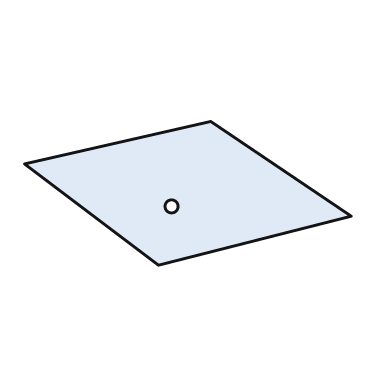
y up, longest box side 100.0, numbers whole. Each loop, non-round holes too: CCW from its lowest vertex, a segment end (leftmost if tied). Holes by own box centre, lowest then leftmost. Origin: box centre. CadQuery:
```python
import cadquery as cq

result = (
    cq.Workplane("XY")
    .moveTo(-9.0, -22.0)
    .lineTo(50.0, -7.0)
    .lineTo(7.0, 22.0)
    .lineTo(-50.0, 9.0)
    .close()
    .moveTo(-5.0, -4.0)
    .circle(2.0)
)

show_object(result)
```